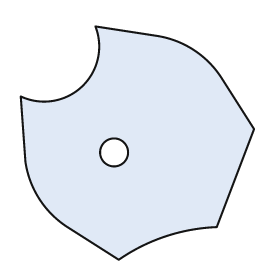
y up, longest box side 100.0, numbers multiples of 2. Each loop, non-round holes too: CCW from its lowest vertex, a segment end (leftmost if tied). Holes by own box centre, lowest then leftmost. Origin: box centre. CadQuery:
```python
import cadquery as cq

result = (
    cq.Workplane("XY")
    .moveTo(-8.0, -50.0)
    .threePointArc((12.0, -40.0), (34.0, -36.0))
    .lineTo(50.0, 6.0)
    .lineTo(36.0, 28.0)
    .threePointArc((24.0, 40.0), (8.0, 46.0))
    .lineTo(-18.0, 50.0)
    .threePointArc((-24.0, 24.0), (-50.0, 20.0))
    .lineTo(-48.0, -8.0)
    .threePointArc((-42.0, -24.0), (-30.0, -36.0))
    .close()
    .moveTo(-10.0, -4.0)
    .circle(6.0)
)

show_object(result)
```